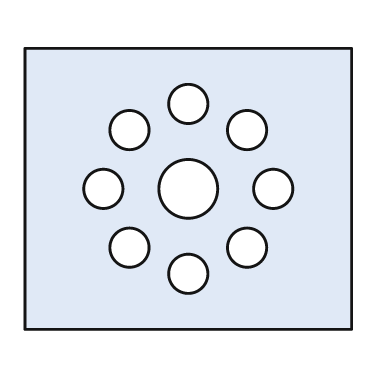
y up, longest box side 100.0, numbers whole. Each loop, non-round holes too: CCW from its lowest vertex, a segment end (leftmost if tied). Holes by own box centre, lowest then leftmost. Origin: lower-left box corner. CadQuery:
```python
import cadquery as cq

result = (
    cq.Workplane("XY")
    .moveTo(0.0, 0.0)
    .lineTo(100.0, 0.0)
    .lineTo(100.0, 86.0)
    .lineTo(0.0, 86.0)
    .close()
    .moveTo(50.0, 17.0)
    .circle(6.0)
    .moveTo(32.0, 25.0)
    .circle(6.0)
    .moveTo(68.0, 25.0)
    .circle(6.0)
    .moveTo(24.0, 43.0)
    .circle(6.0)
    .moveTo(50.0, 43.0)
    .circle(9.0)
    .moveTo(76.0, 43.0)
    .circle(6.0)
    .moveTo(32.0, 61.0)
    .circle(6.0)
    .moveTo(68.0, 61.0)
    .circle(6.0)
    .moveTo(50.0, 69.0)
    .circle(6.0)
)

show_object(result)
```